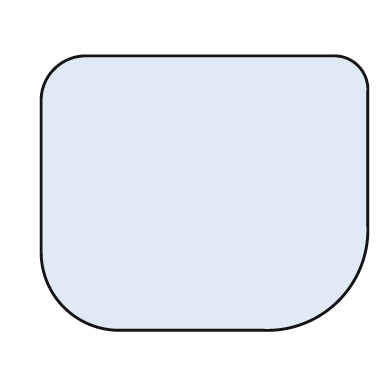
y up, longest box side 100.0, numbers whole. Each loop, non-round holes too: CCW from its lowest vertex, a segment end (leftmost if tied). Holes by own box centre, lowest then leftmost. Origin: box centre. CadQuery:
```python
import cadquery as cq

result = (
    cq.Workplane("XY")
    .moveTo(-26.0, -42.0)
    .lineTo(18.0, -42.0)
    .threePointArc((41.0, -33.0), (50.0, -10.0))
    .lineTo(50.0, 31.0)
    .threePointArc((47.0, 39.0), (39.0, 42.0))
    .lineTo(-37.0, 42.0)
    .threePointArc((-46.0, 38.0), (-50.0, 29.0))
    .lineTo(-50.0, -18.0)
    .threePointArc((-43.0, -35.0), (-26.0, -42.0))
    .close()
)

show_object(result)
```